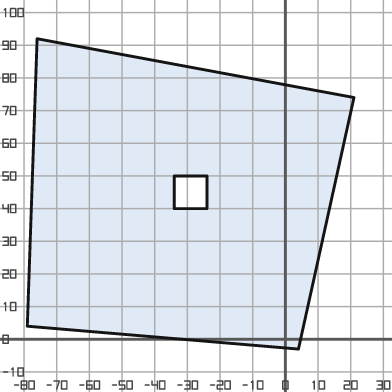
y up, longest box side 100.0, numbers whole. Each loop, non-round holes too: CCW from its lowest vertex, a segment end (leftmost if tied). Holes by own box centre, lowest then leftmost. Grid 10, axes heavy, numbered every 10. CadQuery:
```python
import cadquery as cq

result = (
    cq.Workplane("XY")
    .moveTo(4.0, -3.0)
    .lineTo(21.0, 74.0)
    .lineTo(-76.0, 92.0)
    .lineTo(-79.0, 4.0)
    .close()
    .moveTo(-34.0, 40.0)
    .lineTo(-24.0, 40.0)
    .lineTo(-24.0, 50.0)
    .lineTo(-34.0, 50.0)
    .close()
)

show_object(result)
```